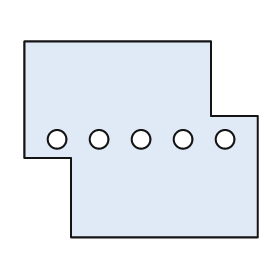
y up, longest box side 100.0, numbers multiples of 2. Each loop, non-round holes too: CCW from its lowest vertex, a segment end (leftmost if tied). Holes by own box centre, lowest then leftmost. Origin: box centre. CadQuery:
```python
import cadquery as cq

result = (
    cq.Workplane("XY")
    .moveTo(-30.0, -42.0)
    .lineTo(50.0, -42.0)
    .lineTo(50.0, 10.0)
    .lineTo(30.0, 10.0)
    .lineTo(30.0, 42.0)
    .lineTo(-50.0, 42.0)
    .lineTo(-50.0, -8.0)
    .lineTo(-30.0, -8.0)
    .close()
    .moveTo(-36.0, 0.0)
    .circle(4.0)
    .moveTo(-18.0, 0.0)
    .circle(4.0)
    .moveTo(0.0, 0.0)
    .circle(4.0)
    .moveTo(18.0, 0.0)
    .circle(4.0)
    .moveTo(36.0, 0.0)
    .circle(4.0)
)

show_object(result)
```